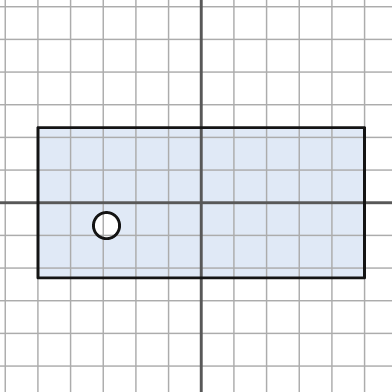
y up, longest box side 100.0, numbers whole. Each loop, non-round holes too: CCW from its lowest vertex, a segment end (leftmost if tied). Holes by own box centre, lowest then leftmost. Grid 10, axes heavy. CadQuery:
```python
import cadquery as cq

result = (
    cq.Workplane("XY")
    .moveTo(-50.0, -23.0)
    .lineTo(50.0, -23.0)
    .lineTo(50.0, 23.0)
    .lineTo(-50.0, 23.0)
    .close()
    .moveTo(-29.0, -7.0)
    .circle(4.0)
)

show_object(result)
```